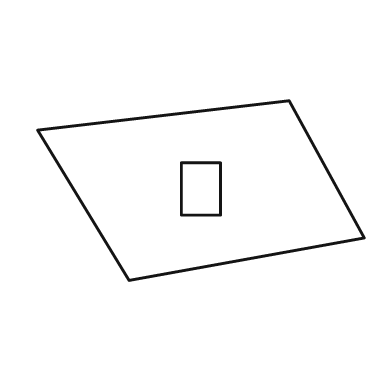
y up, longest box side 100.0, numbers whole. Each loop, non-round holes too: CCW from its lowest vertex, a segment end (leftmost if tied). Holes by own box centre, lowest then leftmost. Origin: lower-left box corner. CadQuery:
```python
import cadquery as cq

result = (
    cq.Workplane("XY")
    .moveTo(28.0, 0.0)
    .lineTo(100.0, 13.0)
    .lineTo(77.0, 55.0)
    .lineTo(0.0, 46.0)
    .close()
    .moveTo(44.0, 20.0)
    .lineTo(56.0, 20.0)
    .lineTo(56.0, 36.0)
    .lineTo(44.0, 36.0)
    .close()
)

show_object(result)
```